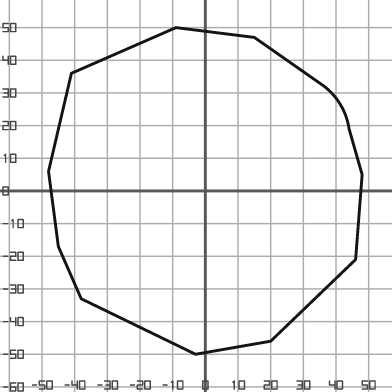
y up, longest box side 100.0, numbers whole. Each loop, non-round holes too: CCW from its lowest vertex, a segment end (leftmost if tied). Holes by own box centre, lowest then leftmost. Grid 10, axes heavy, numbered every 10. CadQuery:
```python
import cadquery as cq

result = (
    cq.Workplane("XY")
    .moveTo(-3.0, -50.0)
    .lineTo(20.0, -46.0)
    .lineTo(46.0, -21.0)
    .lineTo(48.0, 5.0)
    .lineTo(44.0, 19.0)
    .threePointArc((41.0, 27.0), (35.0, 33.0))
    .lineTo(15.0, 47.0)
    .lineTo(-9.0, 50.0)
    .lineTo(-41.0, 36.0)
    .lineTo(-48.0, 6.0)
    .lineTo(-45.0, -17.0)
    .lineTo(-38.0, -33.0)
    .close()
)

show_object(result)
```